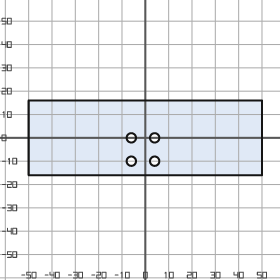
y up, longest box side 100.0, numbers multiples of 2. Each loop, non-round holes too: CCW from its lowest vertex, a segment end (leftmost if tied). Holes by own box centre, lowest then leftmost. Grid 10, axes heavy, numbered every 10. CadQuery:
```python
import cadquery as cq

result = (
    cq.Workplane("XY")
    .moveTo(-50.0, -16.0)
    .lineTo(50.0, -16.0)
    .lineTo(50.0, 16.0)
    .lineTo(-50.0, 16.0)
    .close()
    .moveTo(-6.0, -10.0)
    .circle(2.0)
    .moveTo(4.0, -10.0)
    .circle(2.0)
    .moveTo(-6.0, 0.0)
    .circle(2.0)
    .moveTo(4.0, 0.0)
    .circle(2.0)
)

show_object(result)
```